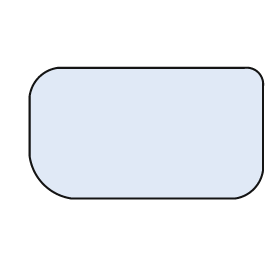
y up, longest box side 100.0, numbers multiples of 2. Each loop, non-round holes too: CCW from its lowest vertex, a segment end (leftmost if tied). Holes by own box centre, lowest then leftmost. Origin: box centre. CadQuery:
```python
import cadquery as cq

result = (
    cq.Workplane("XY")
    .moveTo(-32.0, -28.0)
    .lineTo(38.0, -28.0)
    .threePointArc((46.0, -24.0), (50.0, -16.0))
    .lineTo(50.0, 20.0)
    .threePointArc((48.0, 26.0), (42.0, 28.0))
    .lineTo(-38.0, 28.0)
    .threePointArc((-46.0, 24.0), (-50.0, 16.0))
    .lineTo(-50.0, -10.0)
    .threePointArc((-44.0, -22.0), (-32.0, -28.0))
    .close()
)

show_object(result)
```